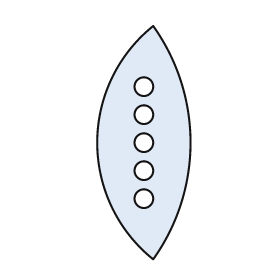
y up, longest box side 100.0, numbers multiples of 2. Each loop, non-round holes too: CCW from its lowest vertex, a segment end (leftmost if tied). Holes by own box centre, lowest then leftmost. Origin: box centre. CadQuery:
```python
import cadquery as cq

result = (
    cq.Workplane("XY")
    .moveTo(4.0, -50.0)
    .threePointArc((20.0, 0.0), (4.0, 50.0))
    .threePointArc((-20.0, 0.0), (4.0, -50.0))
    .close()
    .moveTo(0.0, -24.0)
    .circle(4.0)
    .moveTo(0.0, -12.0)
    .circle(4.0)
    .moveTo(0.0, 0.0)
    .circle(4.0)
    .moveTo(0.0, 12.0)
    .circle(4.0)
    .moveTo(0.0, 24.0)
    .circle(4.0)
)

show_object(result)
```